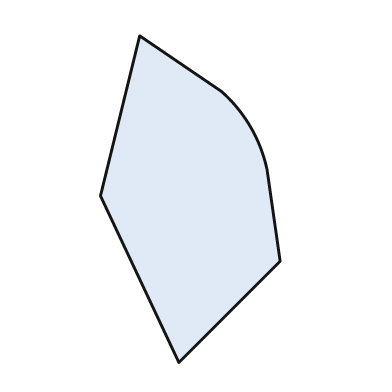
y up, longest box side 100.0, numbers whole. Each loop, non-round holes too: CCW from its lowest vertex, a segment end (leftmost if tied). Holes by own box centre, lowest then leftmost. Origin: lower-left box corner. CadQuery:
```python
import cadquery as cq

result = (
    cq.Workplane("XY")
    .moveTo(24.0, 0.0)
    .lineTo(55.0, 31.0)
    .lineTo(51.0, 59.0)
    .threePointArc((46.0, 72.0), (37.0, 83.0))
    .lineTo(12.0, 100.0)
    .lineTo(0.0, 51.0)
    .close()
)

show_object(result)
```